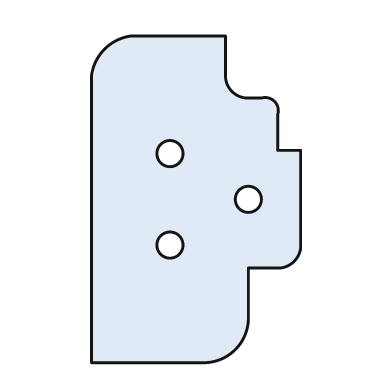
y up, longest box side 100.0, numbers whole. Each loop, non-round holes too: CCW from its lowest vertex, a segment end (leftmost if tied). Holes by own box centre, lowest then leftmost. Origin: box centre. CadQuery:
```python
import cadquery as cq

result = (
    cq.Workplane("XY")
    .moveTo(-32.0, -50.0)
    .lineTo(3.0, -50.0)
    .threePointArc((12.0, -46.0), (16.0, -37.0))
    .lineTo(16.0, -21.0)
    .lineTo(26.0, -21.0)
    .threePointArc((30.0, -19.0), (32.0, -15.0))
    .lineTo(32.0, 15.0)
    .lineTo(25.0, 15.0)
    .lineTo(25.0, 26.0)
    .threePointArc((24.0, 30.0), (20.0, 31.0))
    .lineTo(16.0, 31.0)
    .threePointArc((11.0, 33.0), (9.0, 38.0))
    .lineTo(9.0, 50.0)
    .lineTo(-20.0, 50.0)
    .threePointArc((-28.0, 46.0), (-32.0, 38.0))
    .close()
    .moveTo(-8.0, -14.0)
    .circle(4.0)
    .moveTo(16.0, 0.0)
    .circle(4.0)
    .moveTo(-8.0, 14.0)
    .circle(4.0)
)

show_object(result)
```